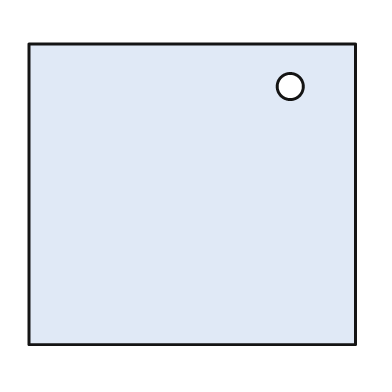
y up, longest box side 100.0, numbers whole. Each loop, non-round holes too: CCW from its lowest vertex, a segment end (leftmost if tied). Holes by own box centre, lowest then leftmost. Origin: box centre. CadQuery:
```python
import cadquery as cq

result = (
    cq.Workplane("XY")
    .moveTo(-50.0, -46.0)
    .lineTo(50.0, -46.0)
    .lineTo(50.0, 46.0)
    .lineTo(-50.0, 46.0)
    .close()
    .moveTo(30.0, 33.0)
    .circle(4.0)
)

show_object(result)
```